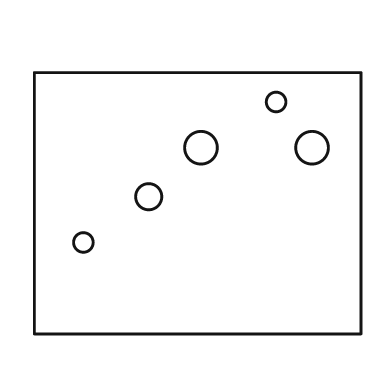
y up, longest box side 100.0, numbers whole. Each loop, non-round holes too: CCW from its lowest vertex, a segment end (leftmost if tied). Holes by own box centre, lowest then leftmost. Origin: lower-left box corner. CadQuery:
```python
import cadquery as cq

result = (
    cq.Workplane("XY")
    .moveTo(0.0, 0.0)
    .lineTo(100.0, 0.0)
    .lineTo(100.0, 80.0)
    .lineTo(0.0, 80.0)
    .close()
    .moveTo(15.0, 28.0)
    .circle(3.0)
    .moveTo(35.0, 42.0)
    .circle(4.0)
    .moveTo(51.0, 57.0)
    .circle(5.0)
    .moveTo(85.0, 57.0)
    .circle(5.0)
    .moveTo(74.0, 71.0)
    .circle(3.0)
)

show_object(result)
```